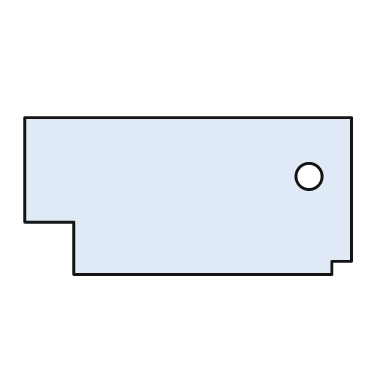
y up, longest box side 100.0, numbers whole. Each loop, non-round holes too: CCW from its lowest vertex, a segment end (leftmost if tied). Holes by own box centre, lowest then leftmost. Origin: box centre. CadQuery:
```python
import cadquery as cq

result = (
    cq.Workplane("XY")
    .moveTo(-35.0, -24.0)
    .lineTo(44.0, -24.0)
    .lineTo(44.0, -20.0)
    .lineTo(50.0, -20.0)
    .lineTo(50.0, 24.0)
    .lineTo(-50.0, 24.0)
    .lineTo(-50.0, -8.0)
    .lineTo(-35.0, -8.0)
    .close()
    .moveTo(37.0, 6.0)
    .circle(4.0)
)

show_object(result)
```